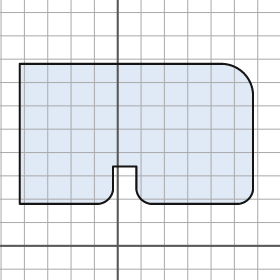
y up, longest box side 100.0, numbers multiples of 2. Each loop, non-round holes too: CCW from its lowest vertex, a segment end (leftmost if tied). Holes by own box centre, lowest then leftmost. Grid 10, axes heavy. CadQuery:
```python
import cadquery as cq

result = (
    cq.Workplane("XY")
    .moveTo(-42.0, 18.0)
    .lineTo(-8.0, 18.0)
    .threePointArc((-4.0, 20.0), (-2.0, 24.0))
    .lineTo(-2.0, 34.0)
    .lineTo(8.0, 34.0)
    .lineTo(8.0, 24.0)
    .threePointArc((10.0, 20.0), (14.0, 18.0))
    .lineTo(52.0, 18.0)
    .threePointArc((56.0, 20.0), (58.0, 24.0))
    .lineTo(58.0, 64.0)
    .threePointArc((54.0, 74.0), (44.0, 78.0))
    .lineTo(-42.0, 78.0)
    .close()
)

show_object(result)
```